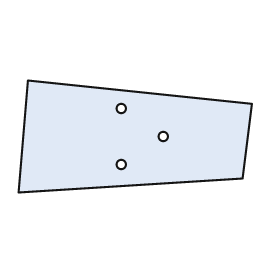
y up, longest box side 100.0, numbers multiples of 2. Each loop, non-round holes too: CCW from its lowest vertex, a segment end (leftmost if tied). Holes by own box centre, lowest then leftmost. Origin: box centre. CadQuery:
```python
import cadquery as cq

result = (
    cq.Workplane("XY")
    .moveTo(-50.0, -24.0)
    .lineTo(46.0, -18.0)
    .lineTo(50.0, 14.0)
    .lineTo(-46.0, 24.0)
    .close()
    .moveTo(-6.0, -12.0)
    .circle(2.0)
    .moveTo(12.0, 0.0)
    .circle(2.0)
    .moveTo(-6.0, 12.0)
    .circle(2.0)
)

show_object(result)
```